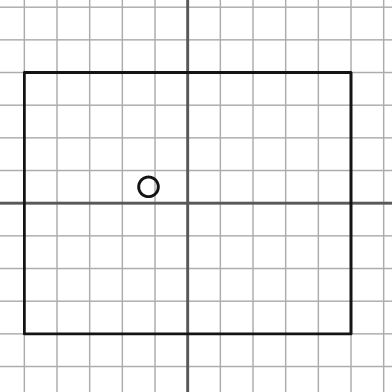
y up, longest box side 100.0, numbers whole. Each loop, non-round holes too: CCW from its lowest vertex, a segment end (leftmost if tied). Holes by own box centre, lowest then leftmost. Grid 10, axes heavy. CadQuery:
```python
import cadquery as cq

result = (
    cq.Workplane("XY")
    .moveTo(-50.0, -40.0)
    .lineTo(50.0, -40.0)
    .lineTo(50.0, 40.0)
    .lineTo(-50.0, 40.0)
    .close()
    .moveTo(-12.0, 5.0)
    .circle(3.0)
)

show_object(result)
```